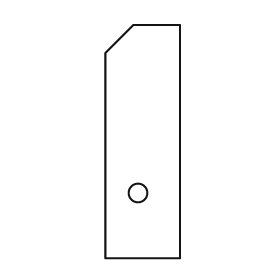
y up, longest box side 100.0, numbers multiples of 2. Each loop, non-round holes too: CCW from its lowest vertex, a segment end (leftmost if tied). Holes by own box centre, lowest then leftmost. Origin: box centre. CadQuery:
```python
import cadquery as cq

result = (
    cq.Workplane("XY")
    .moveTo(-16.0, -50.0)
    .lineTo(16.0, -50.0)
    .lineTo(16.0, 50.0)
    .lineTo(-4.0, 50.0)
    .lineTo(-16.0, 38.0)
    .close()
    .moveTo(-2.0, -22.0)
    .circle(4.0)
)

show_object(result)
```